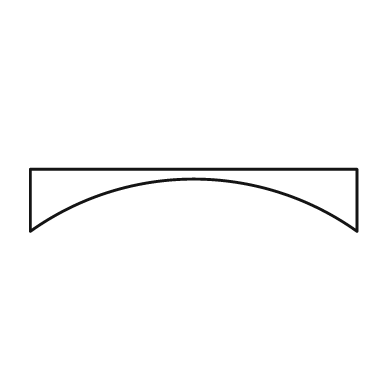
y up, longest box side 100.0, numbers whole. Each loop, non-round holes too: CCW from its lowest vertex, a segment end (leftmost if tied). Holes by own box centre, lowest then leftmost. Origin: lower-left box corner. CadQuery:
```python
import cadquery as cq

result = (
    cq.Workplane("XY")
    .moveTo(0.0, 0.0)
    .threePointArc((50.0, 16.0), (100.0, 0.0))
    .lineTo(100.0, 19.0)
    .lineTo(0.0, 19.0)
    .close()
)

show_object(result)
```